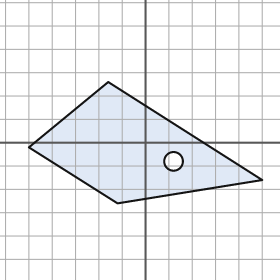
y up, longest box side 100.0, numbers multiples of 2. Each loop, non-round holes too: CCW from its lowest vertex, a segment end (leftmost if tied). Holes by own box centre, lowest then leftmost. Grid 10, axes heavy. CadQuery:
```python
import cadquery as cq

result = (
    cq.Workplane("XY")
    .moveTo(-12.0, -26.0)
    .lineTo(50.0, -16.0)
    .lineTo(-16.0, 26.0)
    .lineTo(-50.0, -2.0)
    .close()
    .moveTo(12.0, -8.0)
    .circle(4.0)
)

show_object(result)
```